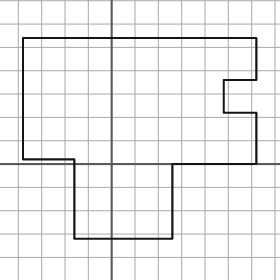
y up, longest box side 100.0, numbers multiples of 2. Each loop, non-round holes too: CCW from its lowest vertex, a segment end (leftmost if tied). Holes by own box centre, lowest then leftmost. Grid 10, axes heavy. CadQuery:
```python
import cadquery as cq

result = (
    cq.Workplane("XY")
    .moveTo(-16.0, -32.0)
    .lineTo(26.0, -32.0)
    .lineTo(26.0, 0.0)
    .lineTo(62.0, 0.0)
    .lineTo(62.0, 22.0)
    .lineTo(48.0, 22.0)
    .lineTo(48.0, 36.0)
    .lineTo(62.0, 36.0)
    .lineTo(62.0, 54.0)
    .lineTo(-38.0, 54.0)
    .lineTo(-38.0, 2.0)
    .lineTo(-16.0, 2.0)
    .close()
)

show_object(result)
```